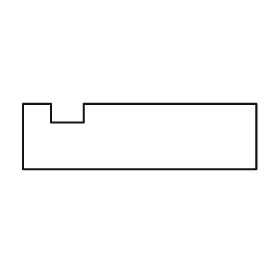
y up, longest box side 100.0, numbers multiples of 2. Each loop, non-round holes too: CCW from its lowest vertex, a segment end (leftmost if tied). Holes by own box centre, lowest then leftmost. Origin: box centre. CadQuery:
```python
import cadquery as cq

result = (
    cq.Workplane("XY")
    .moveTo(-50.0, -14.0)
    .lineTo(50.0, -14.0)
    .lineTo(50.0, 14.0)
    .lineTo(-24.0, 14.0)
    .lineTo(-24.0, 6.0)
    .lineTo(-38.0, 6.0)
    .lineTo(-38.0, 14.0)
    .lineTo(-50.0, 14.0)
    .close()
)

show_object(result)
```